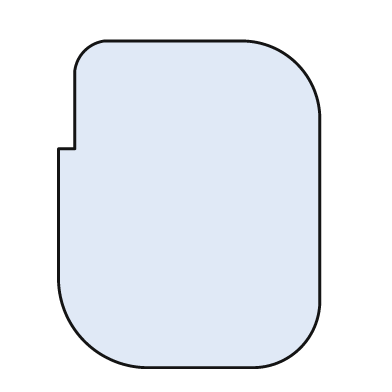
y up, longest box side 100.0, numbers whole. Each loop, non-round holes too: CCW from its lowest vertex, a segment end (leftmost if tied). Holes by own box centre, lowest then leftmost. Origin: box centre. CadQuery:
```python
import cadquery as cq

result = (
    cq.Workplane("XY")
    .moveTo(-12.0, -50.0)
    .lineTo(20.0, -50.0)
    .threePointArc((34.0, -44.0), (40.0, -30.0))
    .lineTo(40.0, 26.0)
    .threePointArc((33.0, 43.0), (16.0, 50.0))
    .lineTo(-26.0, 50.0)
    .threePointArc((-32.0, 47.0), (-35.0, 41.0))
    .lineTo(-35.0, 17.0)
    .lineTo(-40.0, 17.0)
    .lineTo(-40.0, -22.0)
    .threePointArc((-32.0, -42.0), (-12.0, -50.0))
    .close()
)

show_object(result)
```